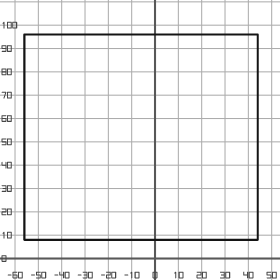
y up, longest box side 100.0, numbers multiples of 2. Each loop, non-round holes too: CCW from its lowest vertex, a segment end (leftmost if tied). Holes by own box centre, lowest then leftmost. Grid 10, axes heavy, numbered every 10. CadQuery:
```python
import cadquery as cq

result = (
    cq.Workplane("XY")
    .moveTo(-56.0, 8.0)
    .lineTo(44.0, 8.0)
    .lineTo(44.0, 96.0)
    .lineTo(-56.0, 96.0)
    .close()
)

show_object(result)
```